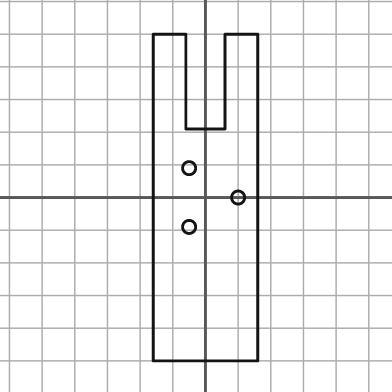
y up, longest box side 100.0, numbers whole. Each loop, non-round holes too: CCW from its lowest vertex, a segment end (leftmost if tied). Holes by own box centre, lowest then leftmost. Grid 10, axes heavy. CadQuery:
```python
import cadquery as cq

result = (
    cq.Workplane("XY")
    .moveTo(-16.0, -50.0)
    .lineTo(16.0, -50.0)
    .lineTo(16.0, 50.0)
    .lineTo(6.0, 50.0)
    .lineTo(6.0, 21.0)
    .lineTo(-6.0, 21.0)
    .lineTo(-6.0, 50.0)
    .lineTo(-16.0, 50.0)
    .close()
    .moveTo(-5.0, -9.0)
    .circle(2.0)
    .moveTo(10.0, 0.0)
    .circle(2.0)
    .moveTo(-5.0, 9.0)
    .circle(2.0)
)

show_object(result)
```